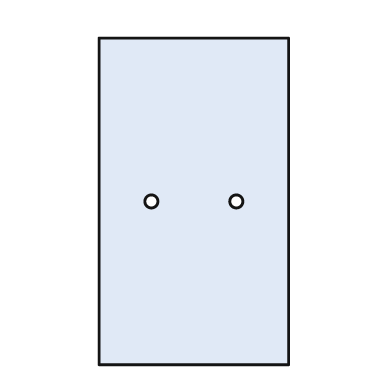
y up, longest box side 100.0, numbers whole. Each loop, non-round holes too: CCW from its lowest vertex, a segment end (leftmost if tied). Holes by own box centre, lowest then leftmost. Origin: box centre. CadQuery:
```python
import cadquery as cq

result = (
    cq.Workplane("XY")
    .moveTo(-29.0, -50.0)
    .lineTo(29.0, -50.0)
    .lineTo(29.0, 50.0)
    .lineTo(-29.0, 50.0)
    .close()
    .moveTo(-13.0, 0.0)
    .circle(2.0)
    .moveTo(13.0, 0.0)
    .circle(2.0)
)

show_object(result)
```